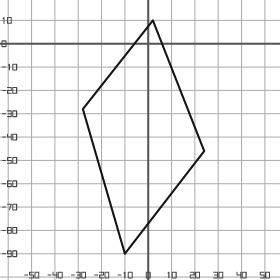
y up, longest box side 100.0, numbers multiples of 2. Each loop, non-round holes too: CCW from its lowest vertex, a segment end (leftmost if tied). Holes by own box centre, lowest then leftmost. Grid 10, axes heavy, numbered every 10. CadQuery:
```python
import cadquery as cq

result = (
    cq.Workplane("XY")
    .moveTo(-10.0, -90.0)
    .lineTo(24.0, -46.0)
    .lineTo(2.0, 10.0)
    .lineTo(-28.0, -28.0)
    .close()
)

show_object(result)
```